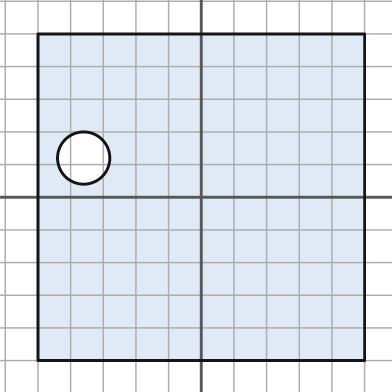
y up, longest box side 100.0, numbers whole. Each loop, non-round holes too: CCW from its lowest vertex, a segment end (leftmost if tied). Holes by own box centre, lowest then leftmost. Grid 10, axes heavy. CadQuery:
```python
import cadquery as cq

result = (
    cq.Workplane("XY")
    .moveTo(-50.0, -50.0)
    .lineTo(50.0, -50.0)
    .lineTo(50.0, 50.0)
    .lineTo(-50.0, 50.0)
    .close()
    .moveTo(-36.0, 12.0)
    .circle(8.0)
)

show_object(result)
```